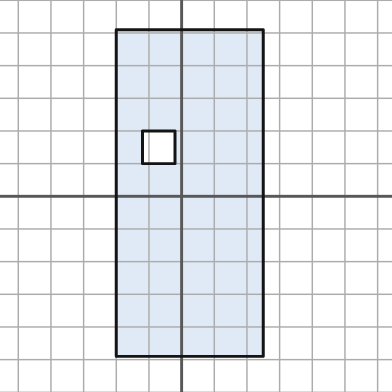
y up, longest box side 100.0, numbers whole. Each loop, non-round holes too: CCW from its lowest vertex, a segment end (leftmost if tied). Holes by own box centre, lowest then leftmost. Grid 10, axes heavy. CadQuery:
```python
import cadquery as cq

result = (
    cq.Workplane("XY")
    .moveTo(-20.0, -49.0)
    .lineTo(25.0, -49.0)
    .lineTo(25.0, 51.0)
    .lineTo(-20.0, 51.0)
    .close()
    .moveTo(-12.0, 10.0)
    .lineTo(-2.0, 10.0)
    .lineTo(-2.0, 20.0)
    .lineTo(-12.0, 20.0)
    .close()
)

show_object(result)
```